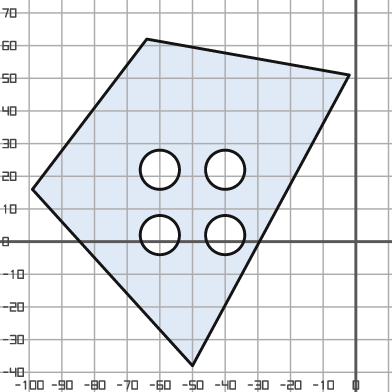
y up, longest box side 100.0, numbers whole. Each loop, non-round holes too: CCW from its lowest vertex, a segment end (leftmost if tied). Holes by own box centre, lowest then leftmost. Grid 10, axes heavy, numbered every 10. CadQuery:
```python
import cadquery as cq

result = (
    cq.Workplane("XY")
    .moveTo(-50.0, -38.0)
    .lineTo(-2.0, 51.0)
    .lineTo(-64.0, 62.0)
    .lineTo(-99.0, 16.0)
    .close()
    .moveTo(-60.0, 2.0)
    .circle(6.0)
    .moveTo(-40.0, 2.0)
    .circle(6.0)
    .moveTo(-60.0, 22.0)
    .circle(6.0)
    .moveTo(-40.0, 22.0)
    .circle(6.0)
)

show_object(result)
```